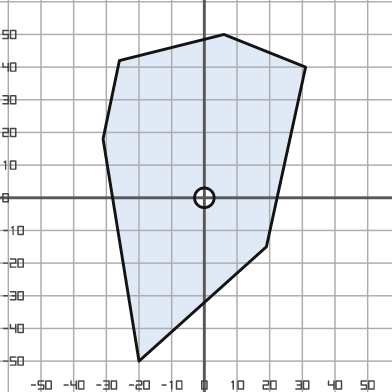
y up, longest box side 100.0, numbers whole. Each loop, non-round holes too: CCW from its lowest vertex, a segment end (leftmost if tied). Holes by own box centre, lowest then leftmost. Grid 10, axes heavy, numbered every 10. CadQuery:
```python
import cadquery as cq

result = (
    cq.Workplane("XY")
    .moveTo(-20.0, -50.0)
    .lineTo(19.0, -15.0)
    .lineTo(31.0, 40.0)
    .lineTo(6.0, 50.0)
    .lineTo(-26.0, 42.0)
    .lineTo(-31.0, 18.0)
    .close()
    .moveTo(0.0, 0.0)
    .circle(3.0)
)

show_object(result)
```